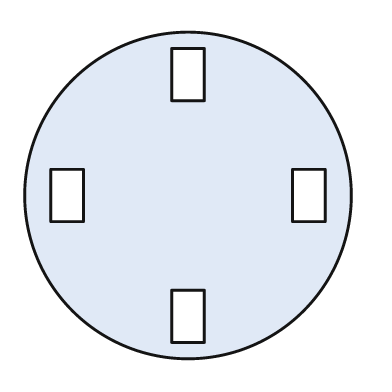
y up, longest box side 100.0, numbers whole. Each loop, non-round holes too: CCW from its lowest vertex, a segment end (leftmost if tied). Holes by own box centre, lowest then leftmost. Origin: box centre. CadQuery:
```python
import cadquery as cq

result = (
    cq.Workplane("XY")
    .moveTo(0.0, 0.0)
    .circle(50.0)
    .moveTo(-5.0, -45.0)
    .lineTo(5.0, -45.0)
    .lineTo(5.0, -29.0)
    .lineTo(-5.0, -29.0)
    .close()
    .moveTo(-42.0, -8.0)
    .lineTo(-32.0, -8.0)
    .lineTo(-32.0, 8.0)
    .lineTo(-42.0, 8.0)
    .close()
    .moveTo(32.0, -8.0)
    .lineTo(42.0, -8.0)
    .lineTo(42.0, 8.0)
    .lineTo(32.0, 8.0)
    .close()
    .moveTo(-5.0, 29.0)
    .lineTo(5.0, 29.0)
    .lineTo(5.0, 45.0)
    .lineTo(-5.0, 45.0)
    .close()
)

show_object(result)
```